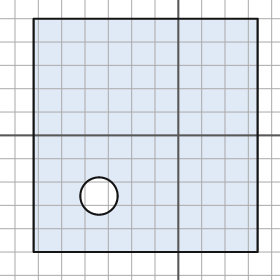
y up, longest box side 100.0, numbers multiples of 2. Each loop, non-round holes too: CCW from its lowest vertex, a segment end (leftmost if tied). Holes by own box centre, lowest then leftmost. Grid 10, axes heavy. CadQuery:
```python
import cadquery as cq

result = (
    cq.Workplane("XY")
    .moveTo(-62.0, -50.0)
    .lineTo(34.0, -50.0)
    .lineTo(34.0, 50.0)
    .lineTo(-62.0, 50.0)
    .close()
    .moveTo(-34.0, -26.0)
    .circle(8.0)
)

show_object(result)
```